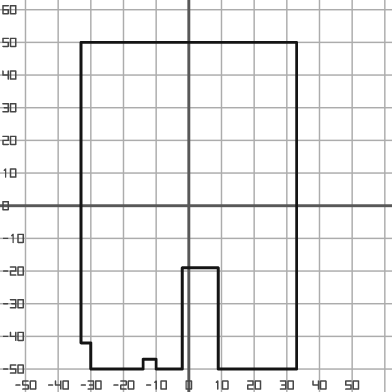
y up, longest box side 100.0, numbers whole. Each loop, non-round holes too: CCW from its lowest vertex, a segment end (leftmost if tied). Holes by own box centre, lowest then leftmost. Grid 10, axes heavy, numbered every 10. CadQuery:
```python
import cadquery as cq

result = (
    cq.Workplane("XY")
    .moveTo(-30.0, -50.0)
    .lineTo(-14.0, -50.0)
    .lineTo(-14.0, -47.0)
    .lineTo(-10.0, -47.0)
    .lineTo(-10.0, -50.0)
    .lineTo(-2.0, -50.0)
    .lineTo(-2.0, -19.0)
    .lineTo(9.0, -19.0)
    .lineTo(9.0, -50.0)
    .lineTo(33.0, -50.0)
    .lineTo(33.0, 50.0)
    .lineTo(-33.0, 50.0)
    .lineTo(-33.0, -42.0)
    .lineTo(-30.0, -42.0)
    .close()
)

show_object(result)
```